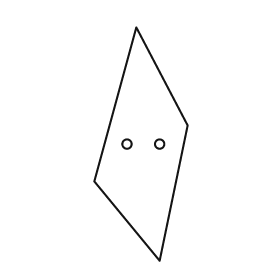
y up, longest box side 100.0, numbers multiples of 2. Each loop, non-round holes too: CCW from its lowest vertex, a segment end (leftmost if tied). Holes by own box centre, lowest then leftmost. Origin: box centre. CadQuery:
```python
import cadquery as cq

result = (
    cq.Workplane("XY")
    .moveTo(8.0, -50.0)
    .lineTo(20.0, 8.0)
    .lineTo(-2.0, 50.0)
    .lineTo(-20.0, -16.0)
    .close()
    .moveTo(-6.0, 0.0)
    .circle(2.0)
    .moveTo(8.0, 0.0)
    .circle(2.0)
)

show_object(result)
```